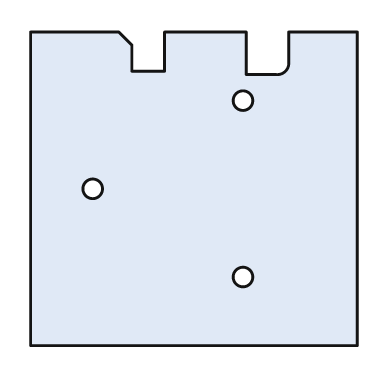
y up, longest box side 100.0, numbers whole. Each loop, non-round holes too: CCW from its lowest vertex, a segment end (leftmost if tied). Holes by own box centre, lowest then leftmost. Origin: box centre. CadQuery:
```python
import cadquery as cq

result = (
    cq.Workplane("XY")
    .moveTo(-50.0, -48.0)
    .lineTo(50.0, -48.0)
    .lineTo(50.0, 48.0)
    .lineTo(29.0, 48.0)
    .lineTo(29.0, 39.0)
    .threePointArc((28.0, 36.0), (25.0, 35.0))
    .lineTo(16.0, 35.0)
    .lineTo(16.0, 48.0)
    .lineTo(-9.0, 48.0)
    .lineTo(-9.0, 36.0)
    .lineTo(-19.0, 36.0)
    .lineTo(-19.0, 44.0)
    .lineTo(-23.0, 48.0)
    .lineTo(-50.0, 48.0)
    .close()
    .moveTo(15.0, -27.0)
    .circle(3.0)
    .moveTo(-31.0, 0.0)
    .circle(3.0)
    .moveTo(15.0, 27.0)
    .circle(3.0)
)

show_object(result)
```